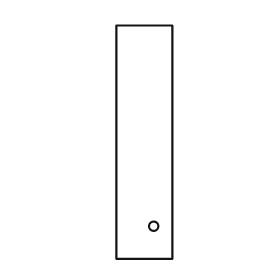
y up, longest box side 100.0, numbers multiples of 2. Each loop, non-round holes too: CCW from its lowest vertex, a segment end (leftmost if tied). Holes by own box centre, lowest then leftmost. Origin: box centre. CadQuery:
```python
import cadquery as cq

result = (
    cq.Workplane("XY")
    .moveTo(-12.0, -50.0)
    .lineTo(12.0, -50.0)
    .lineTo(12.0, 50.0)
    .lineTo(-12.0, 50.0)
    .close()
    .moveTo(4.0, -36.0)
    .circle(2.0)
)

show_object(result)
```